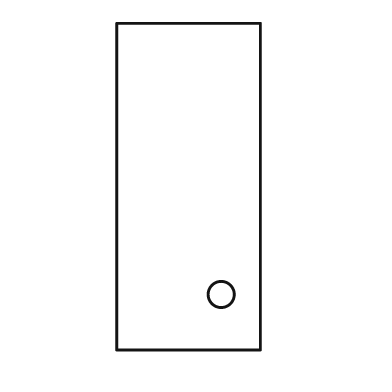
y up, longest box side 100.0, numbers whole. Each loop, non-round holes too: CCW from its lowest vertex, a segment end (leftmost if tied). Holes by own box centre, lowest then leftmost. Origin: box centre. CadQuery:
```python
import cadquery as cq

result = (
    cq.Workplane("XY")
    .moveTo(-22.0, -50.0)
    .lineTo(22.0, -50.0)
    .lineTo(22.0, 50.0)
    .lineTo(-22.0, 50.0)
    .close()
    .moveTo(10.0, -33.0)
    .circle(4.0)
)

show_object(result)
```